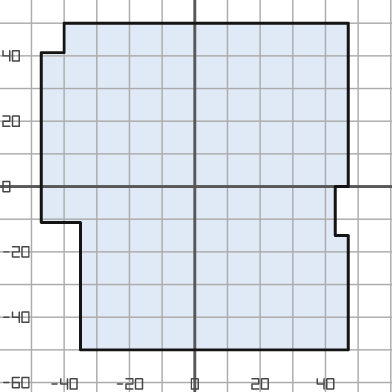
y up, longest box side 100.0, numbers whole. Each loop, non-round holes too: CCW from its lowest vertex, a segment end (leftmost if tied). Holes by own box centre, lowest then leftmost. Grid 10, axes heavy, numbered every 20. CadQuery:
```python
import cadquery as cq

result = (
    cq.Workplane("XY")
    .moveTo(-35.0, -50.0)
    .lineTo(47.0, -50.0)
    .lineTo(47.0, -15.0)
    .lineTo(43.0, -15.0)
    .lineTo(43.0, 0.0)
    .lineTo(47.0, 0.0)
    .lineTo(47.0, 50.0)
    .lineTo(-40.0, 50.0)
    .lineTo(-40.0, 41.0)
    .lineTo(-47.0, 41.0)
    .lineTo(-47.0, -11.0)
    .lineTo(-35.0, -11.0)
    .close()
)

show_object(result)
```